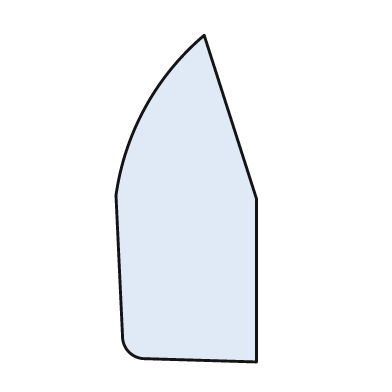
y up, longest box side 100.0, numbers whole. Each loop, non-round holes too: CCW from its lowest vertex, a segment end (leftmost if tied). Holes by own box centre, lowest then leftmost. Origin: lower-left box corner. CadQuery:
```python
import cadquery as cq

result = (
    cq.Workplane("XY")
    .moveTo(43.0, 0.0)
    .lineTo(43.0, 50.0)
    .lineTo(27.0, 100.0)
    .threePointArc((9.0, 78.0), (0.0, 51.0))
    .lineTo(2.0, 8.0)
    .threePointArc((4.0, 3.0), (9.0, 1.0))
    .close()
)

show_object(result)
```